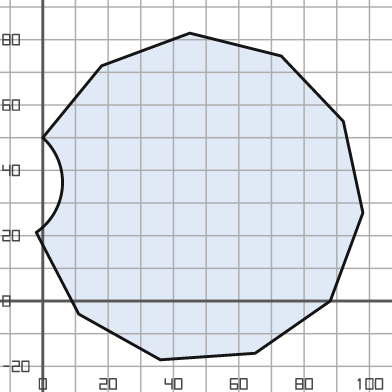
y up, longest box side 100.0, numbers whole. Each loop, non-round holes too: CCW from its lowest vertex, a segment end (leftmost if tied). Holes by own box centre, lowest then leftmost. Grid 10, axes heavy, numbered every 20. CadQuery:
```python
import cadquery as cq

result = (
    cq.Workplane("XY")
    .moveTo(36.0, -18.0)
    .lineTo(65.0, -16.0)
    .lineTo(88.0, 0.0)
    .lineTo(98.0, 27.0)
    .lineTo(92.0, 55.0)
    .lineTo(73.0, 75.0)
    .lineTo(45.0, 82.0)
    .lineTo(18.0, 72.0)
    .lineTo(0.0, 50.0)
    .threePointArc((6.0, 35.0), (-2.0, 21.0))
    .lineTo(11.0, -4.0)
    .close()
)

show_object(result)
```